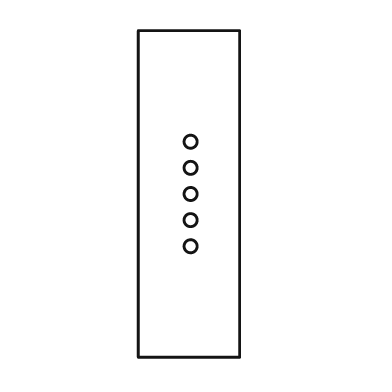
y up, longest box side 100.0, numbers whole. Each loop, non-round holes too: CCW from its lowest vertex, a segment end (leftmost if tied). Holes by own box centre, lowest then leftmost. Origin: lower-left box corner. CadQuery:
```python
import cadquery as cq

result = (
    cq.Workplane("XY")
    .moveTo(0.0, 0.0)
    .lineTo(31.0, 0.0)
    .lineTo(31.0, 100.0)
    .lineTo(0.0, 100.0)
    .close()
    .moveTo(16.0, 34.0)
    .circle(2.0)
    .moveTo(16.0, 42.0)
    .circle(2.0)
    .moveTo(16.0, 50.0)
    .circle(2.0)
    .moveTo(16.0, 58.0)
    .circle(2.0)
    .moveTo(16.0, 66.0)
    .circle(2.0)
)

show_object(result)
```